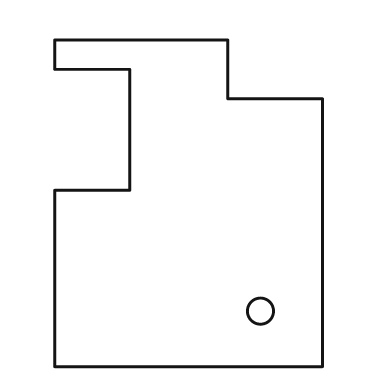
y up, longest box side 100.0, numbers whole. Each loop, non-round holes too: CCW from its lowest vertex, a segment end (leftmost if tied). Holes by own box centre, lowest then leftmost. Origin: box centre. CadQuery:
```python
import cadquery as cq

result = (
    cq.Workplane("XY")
    .moveTo(-41.0, -50.0)
    .lineTo(41.0, -50.0)
    .lineTo(41.0, 32.0)
    .lineTo(12.0, 32.0)
    .lineTo(12.0, 50.0)
    .lineTo(-41.0, 50.0)
    .lineTo(-41.0, 41.0)
    .lineTo(-18.0, 41.0)
    .lineTo(-18.0, 4.0)
    .lineTo(-41.0, 4.0)
    .close()
    .moveTo(22.0, -33.0)
    .circle(4.0)
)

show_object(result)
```